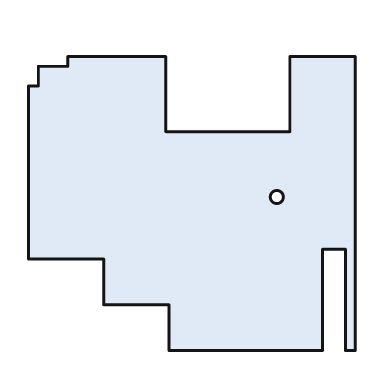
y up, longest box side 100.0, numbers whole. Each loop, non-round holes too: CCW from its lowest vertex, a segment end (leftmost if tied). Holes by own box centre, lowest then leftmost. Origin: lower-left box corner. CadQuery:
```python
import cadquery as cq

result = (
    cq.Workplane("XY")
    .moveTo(43.0, 0.0)
    .lineTo(90.0, 0.0)
    .lineTo(90.0, 31.0)
    .lineTo(97.0, 31.0)
    .lineTo(97.0, 0.0)
    .lineTo(100.0, 0.0)
    .lineTo(100.0, 90.0)
    .lineTo(80.0, 90.0)
    .lineTo(80.0, 67.0)
    .lineTo(42.0, 67.0)
    .lineTo(42.0, 90.0)
    .lineTo(12.0, 90.0)
    .lineTo(12.0, 87.0)
    .lineTo(3.0, 87.0)
    .lineTo(3.0, 81.0)
    .lineTo(0.0, 81.0)
    .lineTo(0.0, 28.0)
    .lineTo(23.0, 28.0)
    .lineTo(23.0, 14.0)
    .lineTo(43.0, 14.0)
    .close()
    .moveTo(76.0, 47.0)
    .circle(2.0)
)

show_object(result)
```